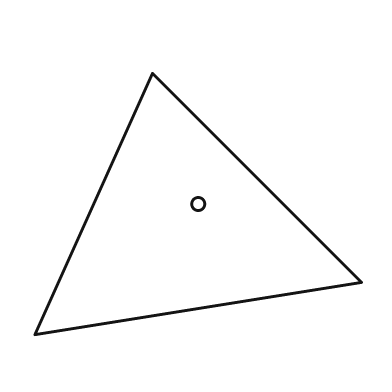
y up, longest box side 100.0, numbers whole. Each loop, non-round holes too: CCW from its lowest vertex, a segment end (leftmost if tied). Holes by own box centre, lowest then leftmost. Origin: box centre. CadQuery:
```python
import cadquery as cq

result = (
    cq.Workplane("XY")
    .moveTo(-50.0, -40.0)
    .lineTo(50.0, -24.0)
    .lineTo(-14.0, 40.0)
    .close()
    .moveTo(0.0, 0.0)
    .circle(2.0)
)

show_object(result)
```